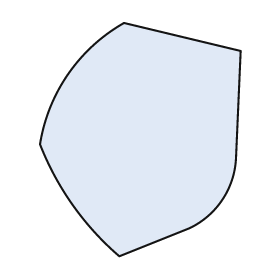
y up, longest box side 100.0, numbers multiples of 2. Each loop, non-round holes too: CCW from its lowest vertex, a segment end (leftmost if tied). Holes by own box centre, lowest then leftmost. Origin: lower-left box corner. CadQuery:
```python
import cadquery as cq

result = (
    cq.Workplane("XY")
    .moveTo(34.0, 0.0)
    .lineTo(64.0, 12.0)
    .threePointArc((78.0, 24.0), (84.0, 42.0))
    .lineTo(86.0, 88.0)
    .lineTo(36.0, 100.0)
    .threePointArc((12.0, 78.0), (0.0, 48.0))
    .threePointArc((14.0, 22.0), (34.0, 0.0))
    .close()
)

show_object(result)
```